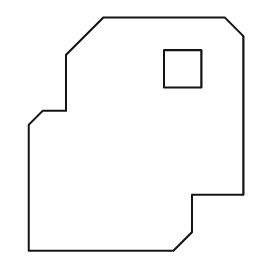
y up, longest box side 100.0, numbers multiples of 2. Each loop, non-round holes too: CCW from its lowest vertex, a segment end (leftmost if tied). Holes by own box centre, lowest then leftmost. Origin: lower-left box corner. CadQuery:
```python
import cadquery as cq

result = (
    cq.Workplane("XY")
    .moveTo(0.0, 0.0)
    .lineTo(62.0, 0.0)
    .lineTo(70.0, 8.0)
    .lineTo(70.0, 24.0)
    .lineTo(92.0, 24.0)
    .lineTo(92.0, 92.0)
    .lineTo(84.0, 100.0)
    .lineTo(32.0, 100.0)
    .lineTo(16.0, 84.0)
    .lineTo(16.0, 60.0)
    .lineTo(6.0, 60.0)
    .lineTo(0.0, 54.0)
    .close()
    .moveTo(58.0, 70.0)
    .lineTo(74.0, 70.0)
    .lineTo(74.0, 86.0)
    .lineTo(58.0, 86.0)
    .close()
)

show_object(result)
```